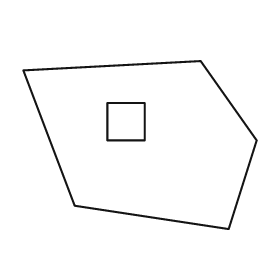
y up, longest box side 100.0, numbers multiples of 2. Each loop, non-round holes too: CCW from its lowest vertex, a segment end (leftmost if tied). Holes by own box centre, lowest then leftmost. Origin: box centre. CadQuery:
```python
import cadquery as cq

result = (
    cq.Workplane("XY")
    .moveTo(38.0, -36.0)
    .lineTo(50.0, 2.0)
    .lineTo(26.0, 36.0)
    .lineTo(-50.0, 32.0)
    .lineTo(-28.0, -26.0)
    .close()
    .moveTo(-14.0, 2.0)
    .lineTo(2.0, 2.0)
    .lineTo(2.0, 18.0)
    .lineTo(-14.0, 18.0)
    .close()
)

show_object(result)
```